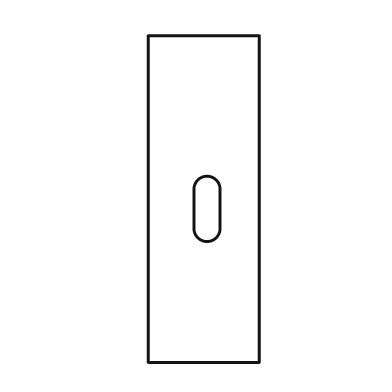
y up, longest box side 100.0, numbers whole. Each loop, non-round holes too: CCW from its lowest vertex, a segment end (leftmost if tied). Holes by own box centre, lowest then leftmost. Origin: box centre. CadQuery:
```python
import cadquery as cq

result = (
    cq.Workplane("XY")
    .moveTo(-17.0, -50.0)
    .lineTo(17.0, -50.0)
    .lineTo(17.0, 50.0)
    .lineTo(-17.0, 50.0)
    .close()
    .moveTo(-3.0, -9.0)
    .threePointArc((1.0, -13.0), (5.0, -9.0))
    .lineTo(5.0, 3.0)
    .threePointArc((1.0, 7.0), (-3.0, 3.0))
    .close()
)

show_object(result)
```